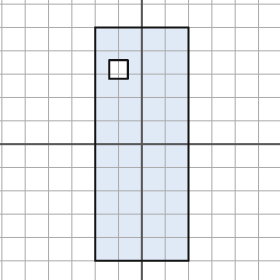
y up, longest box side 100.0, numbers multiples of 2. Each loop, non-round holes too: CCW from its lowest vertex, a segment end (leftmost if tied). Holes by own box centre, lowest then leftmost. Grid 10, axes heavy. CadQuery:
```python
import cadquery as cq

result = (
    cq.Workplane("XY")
    .moveTo(-20.0, -50.0)
    .lineTo(20.0, -50.0)
    .lineTo(20.0, 50.0)
    .lineTo(-20.0, 50.0)
    .close()
    .moveTo(-14.0, 28.0)
    .lineTo(-6.0, 28.0)
    .lineTo(-6.0, 36.0)
    .lineTo(-14.0, 36.0)
    .close()
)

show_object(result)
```